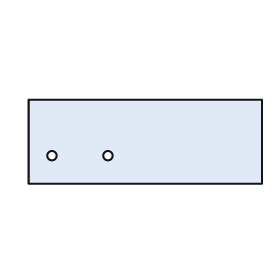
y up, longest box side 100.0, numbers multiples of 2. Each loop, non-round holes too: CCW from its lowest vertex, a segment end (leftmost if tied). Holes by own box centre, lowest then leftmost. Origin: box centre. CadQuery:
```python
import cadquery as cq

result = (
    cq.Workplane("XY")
    .moveTo(-50.0, -18.0)
    .lineTo(50.0, -18.0)
    .lineTo(50.0, 18.0)
    .lineTo(-50.0, 18.0)
    .close()
    .moveTo(-40.0, -6.0)
    .circle(2.0)
    .moveTo(-16.0, -6.0)
    .circle(2.0)
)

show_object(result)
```